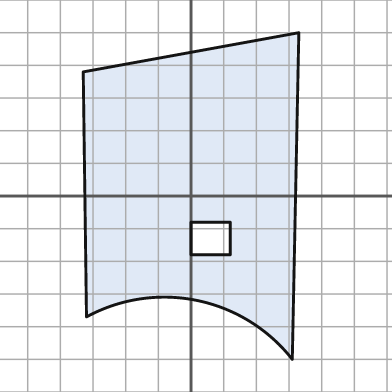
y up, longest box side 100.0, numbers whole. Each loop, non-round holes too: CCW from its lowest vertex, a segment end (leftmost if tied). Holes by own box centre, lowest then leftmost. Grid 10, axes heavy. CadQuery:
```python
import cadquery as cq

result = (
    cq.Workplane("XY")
    .moveTo(31.0, -50.0)
    .lineTo(33.0, 50.0)
    .lineTo(-33.0, 38.0)
    .lineTo(-32.0, -37.0)
    .threePointArc((2.0, -32.0), (31.0, -50.0))
    .close()
    .moveTo(0.0, -18.0)
    .lineTo(12.0, -18.0)
    .lineTo(12.0, -8.0)
    .lineTo(0.0, -8.0)
    .close()
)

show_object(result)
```